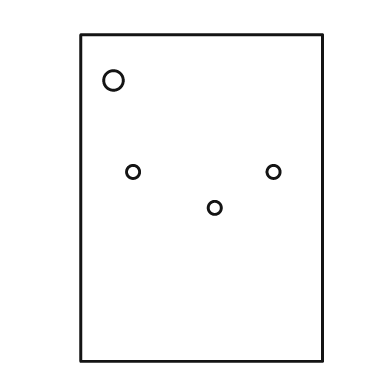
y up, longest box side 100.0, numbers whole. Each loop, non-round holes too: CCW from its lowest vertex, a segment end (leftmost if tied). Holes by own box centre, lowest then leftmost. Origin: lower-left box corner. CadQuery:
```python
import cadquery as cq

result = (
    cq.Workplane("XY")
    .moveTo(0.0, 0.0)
    .lineTo(74.0, 0.0)
    .lineTo(74.0, 100.0)
    .lineTo(0.0, 100.0)
    .close()
    .moveTo(41.0, 47.0)
    .circle(2.0)
    .moveTo(16.0, 58.0)
    .circle(2.0)
    .moveTo(59.0, 58.0)
    .circle(2.0)
    .moveTo(10.0, 86.0)
    .circle(3.0)
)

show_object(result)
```